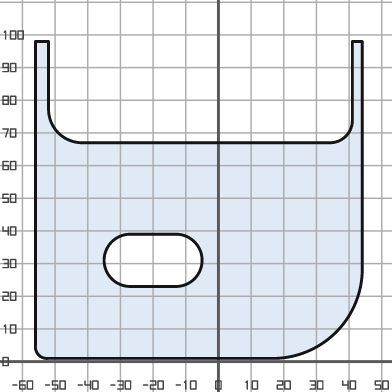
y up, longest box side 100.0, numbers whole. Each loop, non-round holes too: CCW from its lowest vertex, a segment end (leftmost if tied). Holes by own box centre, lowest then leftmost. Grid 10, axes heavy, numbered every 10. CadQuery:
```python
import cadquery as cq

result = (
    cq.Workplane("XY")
    .moveTo(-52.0, 1.0)
    .lineTo(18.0, 1.0)
    .threePointArc((36.0, 9.0), (44.0, 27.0))
    .lineTo(44.0, 98.0)
    .lineTo(41.0, 98.0)
    .lineTo(41.0, 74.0)
    .threePointArc((39.0, 69.0), (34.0, 67.0))
    .lineTo(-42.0, 67.0)
    .threePointArc((-49.0, 70.0), (-52.0, 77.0))
    .lineTo(-52.0, 98.0)
    .lineTo(-56.0, 98.0)
    .lineTo(-56.0, 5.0)
    .threePointArc((-55.0, 2.0), (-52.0, 1.0))
    .close()
    .moveTo(-27.0, 23.0)
    .lineTo(-13.0, 23.0)
    .threePointArc((-5.0, 31.0), (-13.0, 39.0))
    .lineTo(-27.0, 39.0)
    .threePointArc((-35.0, 31.0), (-27.0, 23.0))
    .close()
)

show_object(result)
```